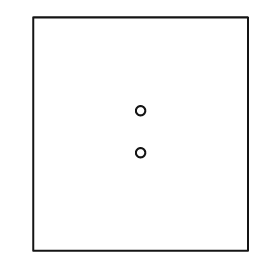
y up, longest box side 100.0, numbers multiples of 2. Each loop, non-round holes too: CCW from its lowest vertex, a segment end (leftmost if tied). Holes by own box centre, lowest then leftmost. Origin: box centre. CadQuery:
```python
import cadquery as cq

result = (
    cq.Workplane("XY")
    .moveTo(-46.0, -50.0)
    .lineTo(46.0, -50.0)
    .lineTo(46.0, 50.0)
    .lineTo(-46.0, 50.0)
    .close()
    .moveTo(0.0, -8.0)
    .circle(2.0)
    .moveTo(0.0, 10.0)
    .circle(2.0)
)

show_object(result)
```